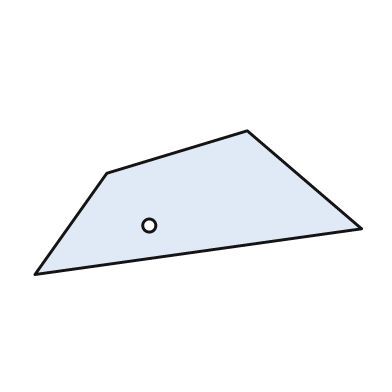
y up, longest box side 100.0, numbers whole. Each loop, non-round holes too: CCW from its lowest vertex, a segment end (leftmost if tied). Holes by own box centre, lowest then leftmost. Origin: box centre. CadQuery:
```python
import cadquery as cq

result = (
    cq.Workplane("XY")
    .moveTo(-50.0, -22.0)
    .lineTo(50.0, -8.0)
    .lineTo(15.0, 22.0)
    .lineTo(-28.0, 9.0)
    .close()
    .moveTo(-15.0, -7.0)
    .circle(2.0)
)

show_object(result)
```